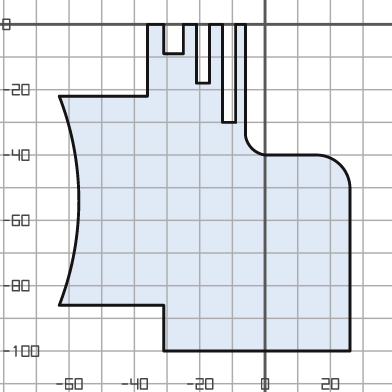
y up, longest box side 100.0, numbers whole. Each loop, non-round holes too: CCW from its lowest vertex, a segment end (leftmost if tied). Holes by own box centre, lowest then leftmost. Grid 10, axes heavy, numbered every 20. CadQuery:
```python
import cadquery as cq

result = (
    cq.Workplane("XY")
    .moveTo(-31.0, -100.0)
    .lineTo(26.0, -100.0)
    .lineTo(26.0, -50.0)
    .threePointArc((23.0, -43.0), (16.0, -40.0))
    .lineTo(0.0, -40.0)
    .threePointArc((-4.0, -38.0), (-6.0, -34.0))
    .lineTo(-6.0, 0.0)
    .lineTo(-9.0, 0.0)
    .lineTo(-9.0, -30.0)
    .lineTo(-13.0, -30.0)
    .lineTo(-13.0, 0.0)
    .lineTo(-17.0, 0.0)
    .lineTo(-17.0, -18.0)
    .lineTo(-21.0, -18.0)
    .lineTo(-21.0, 0.0)
    .lineTo(-25.0, 0.0)
    .lineTo(-25.0, -9.0)
    .lineTo(-31.0, -9.0)
    .lineTo(-31.0, 0.0)
    .lineTo(-36.0, 0.0)
    .lineTo(-36.0, -22.0)
    .lineTo(-63.0, -22.0)
    .threePointArc((-57.0, -54.0), (-63.0, -86.0))
    .lineTo(-31.0, -86.0)
    .close()
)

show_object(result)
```